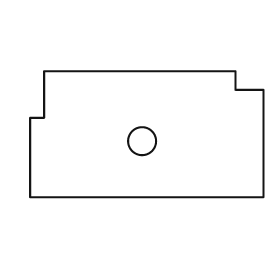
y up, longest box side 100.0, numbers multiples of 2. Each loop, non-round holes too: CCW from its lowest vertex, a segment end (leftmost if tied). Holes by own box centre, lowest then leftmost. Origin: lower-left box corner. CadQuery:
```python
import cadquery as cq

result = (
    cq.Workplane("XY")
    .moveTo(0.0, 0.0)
    .lineTo(100.0, 0.0)
    .lineTo(100.0, 46.0)
    .lineTo(88.0, 46.0)
    .lineTo(88.0, 54.0)
    .lineTo(6.0, 54.0)
    .lineTo(6.0, 34.0)
    .lineTo(0.0, 34.0)
    .close()
    .moveTo(48.0, 24.0)
    .circle(6.0)
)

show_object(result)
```